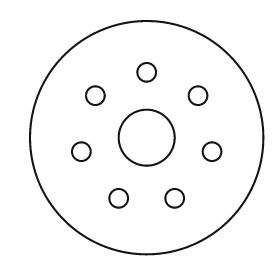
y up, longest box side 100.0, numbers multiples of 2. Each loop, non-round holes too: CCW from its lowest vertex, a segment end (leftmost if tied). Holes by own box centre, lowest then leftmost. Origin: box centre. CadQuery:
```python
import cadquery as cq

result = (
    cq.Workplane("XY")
    .moveTo(0.0, 0.0)
    .circle(50.0)
    .moveTo(-12.0, -26.0)
    .circle(4.0)
    .moveTo(12.0, -26.0)
    .circle(4.0)
    .moveTo(-28.0, -6.0)
    .circle(4.0)
    .moveTo(28.0, -6.0)
    .circle(4.0)
    .moveTo(0.0, 0.0)
    .circle(12.0)
    .moveTo(-22.0, 18.0)
    .circle(4.0)
    .moveTo(22.0, 18.0)
    .circle(4.0)
    .moveTo(0.0, 28.0)
    .circle(4.0)
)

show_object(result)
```